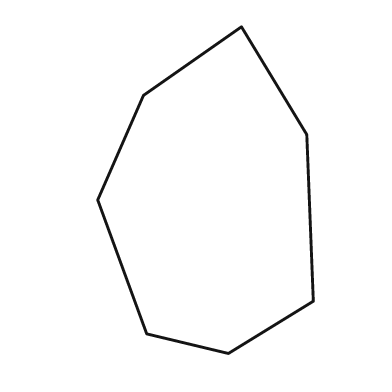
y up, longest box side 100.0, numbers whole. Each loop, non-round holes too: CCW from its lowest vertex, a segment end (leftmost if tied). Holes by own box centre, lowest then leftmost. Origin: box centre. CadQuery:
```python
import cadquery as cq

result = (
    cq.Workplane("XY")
    .moveTo(7.0, -50.0)
    .lineTo(33.0, -34.0)
    .lineTo(31.0, 17.0)
    .lineTo(11.0, 50.0)
    .lineTo(-19.0, 29.0)
    .lineTo(-33.0, -3.0)
    .lineTo(-18.0, -44.0)
    .close()
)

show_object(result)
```